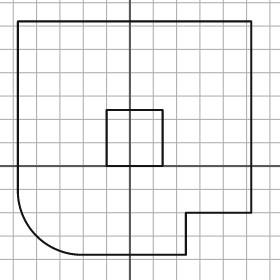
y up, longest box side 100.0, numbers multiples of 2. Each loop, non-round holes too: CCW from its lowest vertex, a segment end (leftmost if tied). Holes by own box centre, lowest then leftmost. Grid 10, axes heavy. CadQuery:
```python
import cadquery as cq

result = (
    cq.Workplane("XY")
    .moveTo(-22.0, -38.0)
    .lineTo(24.0, -38.0)
    .lineTo(24.0, -20.0)
    .lineTo(52.0, -20.0)
    .lineTo(52.0, 62.0)
    .lineTo(-48.0, 62.0)
    .lineTo(-48.0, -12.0)
    .threePointArc((-40.0, -30.0), (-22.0, -38.0))
    .close()
    .moveTo(-10.0, 0.0)
    .lineTo(14.0, 0.0)
    .lineTo(14.0, 24.0)
    .lineTo(-10.0, 24.0)
    .close()
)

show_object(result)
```